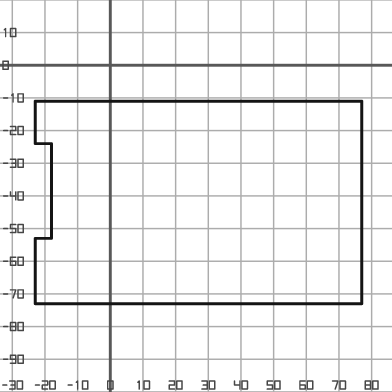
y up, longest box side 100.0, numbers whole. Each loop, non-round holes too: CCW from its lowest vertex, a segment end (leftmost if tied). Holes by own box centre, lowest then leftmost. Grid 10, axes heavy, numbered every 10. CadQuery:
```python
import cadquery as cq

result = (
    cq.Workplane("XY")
    .moveTo(-23.0, -73.0)
    .lineTo(77.0, -73.0)
    .lineTo(77.0, -11.0)
    .lineTo(-23.0, -11.0)
    .lineTo(-23.0, -24.0)
    .lineTo(-18.0, -24.0)
    .lineTo(-18.0, -53.0)
    .lineTo(-23.0, -53.0)
    .close()
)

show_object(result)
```